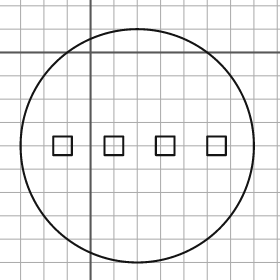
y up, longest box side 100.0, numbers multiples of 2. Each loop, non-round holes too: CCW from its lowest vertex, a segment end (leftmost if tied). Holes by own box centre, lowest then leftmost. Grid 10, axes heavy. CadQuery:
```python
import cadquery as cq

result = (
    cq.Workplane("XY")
    .moveTo(20.0, -40.0)
    .circle(50.0)
    .moveTo(-16.0, -44.0)
    .lineTo(-8.0, -44.0)
    .lineTo(-8.0, -36.0)
    .lineTo(-16.0, -36.0)
    .close()
    .moveTo(6.0, -44.0)
    .lineTo(14.0, -44.0)
    .lineTo(14.0, -36.0)
    .lineTo(6.0, -36.0)
    .close()
    .moveTo(28.0, -44.0)
    .lineTo(36.0, -44.0)
    .lineTo(36.0, -36.0)
    .lineTo(28.0, -36.0)
    .close()
    .moveTo(50.0, -44.0)
    .lineTo(58.0, -44.0)
    .lineTo(58.0, -36.0)
    .lineTo(50.0, -36.0)
    .close()
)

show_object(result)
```